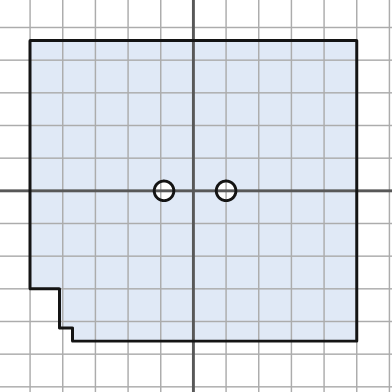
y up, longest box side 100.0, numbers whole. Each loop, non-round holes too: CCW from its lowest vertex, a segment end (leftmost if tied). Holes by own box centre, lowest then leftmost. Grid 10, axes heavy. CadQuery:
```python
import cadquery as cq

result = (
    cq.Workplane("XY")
    .moveTo(-37.0, -46.0)
    .lineTo(50.0, -46.0)
    .lineTo(50.0, 46.0)
    .lineTo(-50.0, 46.0)
    .lineTo(-50.0, -30.0)
    .lineTo(-41.0, -30.0)
    .lineTo(-41.0, -42.0)
    .lineTo(-37.0, -42.0)
    .close()
    .moveTo(-9.0, 0.0)
    .circle(3.0)
    .moveTo(10.0, 0.0)
    .circle(3.0)
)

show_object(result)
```